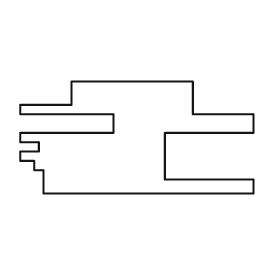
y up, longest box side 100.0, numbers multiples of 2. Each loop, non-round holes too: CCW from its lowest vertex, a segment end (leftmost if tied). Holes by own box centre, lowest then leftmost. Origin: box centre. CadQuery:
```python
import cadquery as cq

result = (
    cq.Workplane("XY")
    .moveTo(-40.0, -24.0)
    .lineTo(50.0, -24.0)
    .lineTo(50.0, -18.0)
    .lineTo(12.0, -18.0)
    .lineTo(12.0, 2.0)
    .lineTo(50.0, 2.0)
    .lineTo(50.0, 10.0)
    .lineTo(24.0, 10.0)
    .lineTo(24.0, 24.0)
    .lineTo(-28.0, 24.0)
    .lineTo(-28.0, 14.0)
    .lineTo(-50.0, 14.0)
    .lineTo(-50.0, 10.0)
    .lineTo(-10.0, 10.0)
    .lineTo(-10.0, 2.0)
    .lineTo(-50.0, 2.0)
    .lineTo(-50.0, -2.0)
    .lineTo(-42.0, -2.0)
    .lineTo(-42.0, -6.0)
    .lineTo(-50.0, -6.0)
    .lineTo(-50.0, -10.0)
    .lineTo(-44.0, -10.0)
    .lineTo(-44.0, -14.0)
    .lineTo(-40.0, -14.0)
    .close()
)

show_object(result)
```